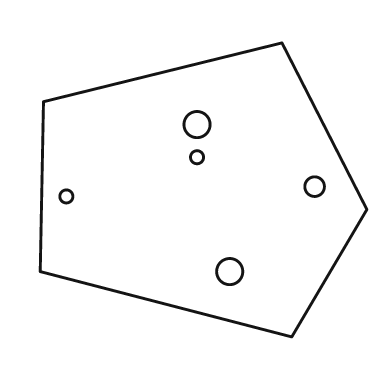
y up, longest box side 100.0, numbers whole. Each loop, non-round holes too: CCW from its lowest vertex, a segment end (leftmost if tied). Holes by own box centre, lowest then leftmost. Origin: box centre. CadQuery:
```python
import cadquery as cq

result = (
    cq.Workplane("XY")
    .moveTo(27.0, -45.0)
    .lineTo(50.0, -6.0)
    .lineTo(24.0, 45.0)
    .lineTo(-49.0, 27.0)
    .lineTo(-50.0, -25.0)
    .close()
    .moveTo(8.0, -25.0)
    .circle(4.0)
    .moveTo(-42.0, -2.0)
    .circle(2.0)
    .moveTo(34.0, 1.0)
    .circle(3.0)
    .moveTo(-2.0, 10.0)
    .circle(2.0)
    .moveTo(-2.0, 20.0)
    .circle(4.0)
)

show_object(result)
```